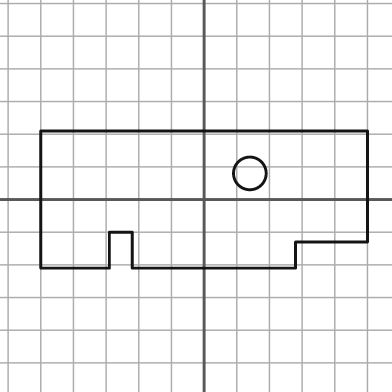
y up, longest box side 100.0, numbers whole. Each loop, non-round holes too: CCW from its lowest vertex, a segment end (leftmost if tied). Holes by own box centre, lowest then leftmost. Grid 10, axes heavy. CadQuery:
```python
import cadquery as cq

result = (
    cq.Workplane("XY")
    .moveTo(-50.0, -21.0)
    .lineTo(-29.0, -21.0)
    .lineTo(-29.0, -10.0)
    .lineTo(-22.0, -10.0)
    .lineTo(-22.0, -21.0)
    .lineTo(28.0, -21.0)
    .lineTo(28.0, -13.0)
    .lineTo(50.0, -13.0)
    .lineTo(50.0, 21.0)
    .lineTo(-50.0, 21.0)
    .close()
    .moveTo(14.0, 8.0)
    .circle(5.0)
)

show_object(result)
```